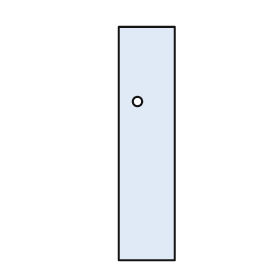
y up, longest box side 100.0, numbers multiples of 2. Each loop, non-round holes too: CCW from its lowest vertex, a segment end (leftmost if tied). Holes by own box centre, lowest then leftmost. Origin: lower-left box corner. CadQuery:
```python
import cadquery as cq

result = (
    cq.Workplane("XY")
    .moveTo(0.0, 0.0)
    .lineTo(24.0, 0.0)
    .lineTo(24.0, 100.0)
    .lineTo(0.0, 100.0)
    .close()
    .moveTo(8.0, 68.0)
    .circle(2.0)
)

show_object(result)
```